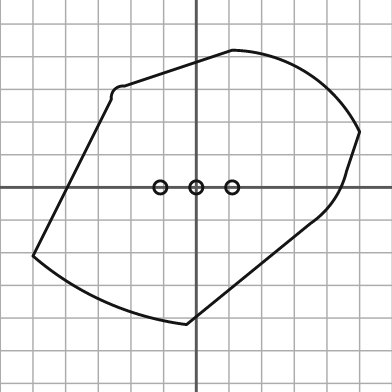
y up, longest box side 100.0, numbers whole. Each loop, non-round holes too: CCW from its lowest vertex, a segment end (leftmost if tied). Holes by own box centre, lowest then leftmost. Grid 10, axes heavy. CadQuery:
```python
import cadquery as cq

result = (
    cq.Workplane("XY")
    .moveTo(-3.0, -42.0)
    .lineTo(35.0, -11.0)
    .threePointArc((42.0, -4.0), (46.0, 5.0))
    .lineTo(50.0, 17.0)
    .threePointArc((34.0, 35.0), (11.0, 42.0))
    .lineTo(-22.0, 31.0)
    .threePointArc((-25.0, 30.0), (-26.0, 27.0))
    .lineTo(-50.0, -21.0)
    .threePointArc((-28.0, -35.0), (-3.0, -42.0))
    .close()
    .moveTo(-11.0, 0.0)
    .circle(2.0)
    .moveTo(0.0, 0.0)
    .circle(2.0)
    .moveTo(11.0, 0.0)
    .circle(2.0)
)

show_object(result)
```